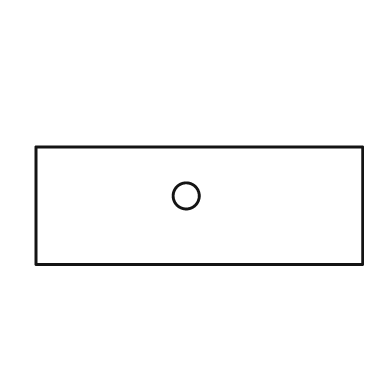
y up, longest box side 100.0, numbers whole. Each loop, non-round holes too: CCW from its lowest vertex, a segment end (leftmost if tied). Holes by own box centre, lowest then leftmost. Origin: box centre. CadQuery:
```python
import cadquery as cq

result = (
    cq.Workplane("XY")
    .moveTo(-50.0, -18.0)
    .lineTo(50.0, -18.0)
    .lineTo(50.0, 18.0)
    .lineTo(-50.0, 18.0)
    .close()
    .moveTo(-4.0, 3.0)
    .circle(4.0)
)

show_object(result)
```